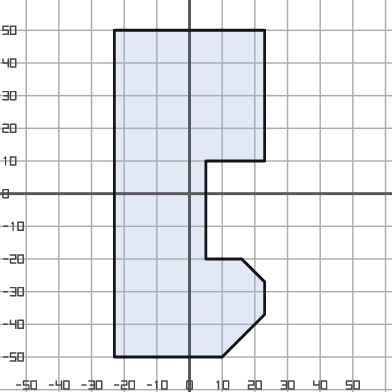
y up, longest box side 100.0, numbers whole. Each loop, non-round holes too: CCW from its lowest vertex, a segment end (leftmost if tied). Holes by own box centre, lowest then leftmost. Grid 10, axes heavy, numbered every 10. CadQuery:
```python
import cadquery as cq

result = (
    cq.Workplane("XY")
    .moveTo(-23.0, -50.0)
    .lineTo(10.0, -50.0)
    .lineTo(23.0, -37.0)
    .lineTo(23.0, -27.0)
    .lineTo(16.0, -20.0)
    .lineTo(5.0, -20.0)
    .lineTo(5.0, 10.0)
    .lineTo(23.0, 10.0)
    .lineTo(23.0, 50.0)
    .lineTo(-23.0, 50.0)
    .close()
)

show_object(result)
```